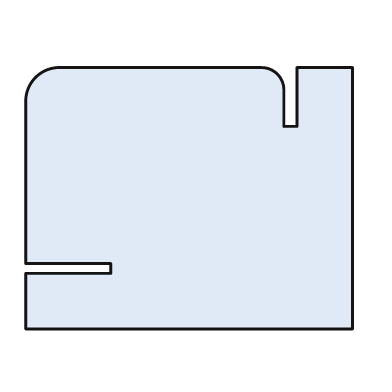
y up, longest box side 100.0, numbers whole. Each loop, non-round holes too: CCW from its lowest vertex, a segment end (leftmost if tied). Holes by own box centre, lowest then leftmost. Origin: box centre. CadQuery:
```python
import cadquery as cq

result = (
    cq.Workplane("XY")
    .moveTo(-50.0, -40.0)
    .lineTo(50.0, -40.0)
    .lineTo(50.0, 40.0)
    .lineTo(33.0, 40.0)
    .lineTo(33.0, 22.0)
    .lineTo(29.0, 22.0)
    .lineTo(29.0, 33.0)
    .threePointArc((27.0, 38.0), (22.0, 40.0))
    .lineTo(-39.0, 40.0)
    .threePointArc((-47.0, 37.0), (-50.0, 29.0))
    .lineTo(-50.0, -20.0)
    .lineTo(-24.0, -20.0)
    .lineTo(-24.0, -23.0)
    .lineTo(-50.0, -23.0)
    .close()
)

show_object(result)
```